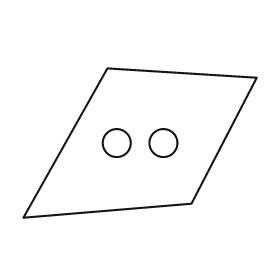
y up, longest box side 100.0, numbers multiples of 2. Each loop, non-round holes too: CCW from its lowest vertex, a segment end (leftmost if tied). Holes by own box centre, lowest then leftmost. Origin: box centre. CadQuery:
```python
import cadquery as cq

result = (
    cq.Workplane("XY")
    .moveTo(-50.0, -32.0)
    .lineTo(22.0, -26.0)
    .lineTo(50.0, 28.0)
    .lineTo(-14.0, 32.0)
    .close()
    .moveTo(-10.0, 0.0)
    .circle(6.0)
    .moveTo(10.0, 0.0)
    .circle(6.0)
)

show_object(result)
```